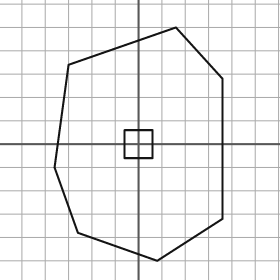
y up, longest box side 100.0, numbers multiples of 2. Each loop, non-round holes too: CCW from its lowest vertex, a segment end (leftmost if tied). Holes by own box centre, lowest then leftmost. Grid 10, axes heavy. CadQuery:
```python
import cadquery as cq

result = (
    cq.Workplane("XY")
    .moveTo(8.0, -50.0)
    .lineTo(36.0, -32.0)
    .lineTo(36.0, 28.0)
    .lineTo(16.0, 50.0)
    .lineTo(-30.0, 34.0)
    .lineTo(-36.0, -10.0)
    .lineTo(-26.0, -38.0)
    .close()
    .moveTo(-6.0, -6.0)
    .lineTo(6.0, -6.0)
    .lineTo(6.0, 6.0)
    .lineTo(-6.0, 6.0)
    .close()
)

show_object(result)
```